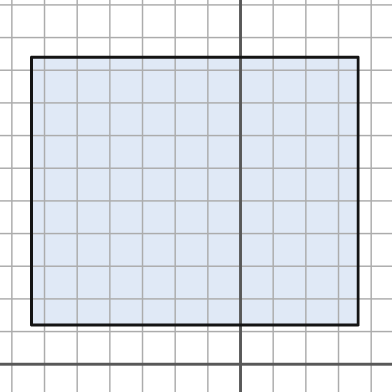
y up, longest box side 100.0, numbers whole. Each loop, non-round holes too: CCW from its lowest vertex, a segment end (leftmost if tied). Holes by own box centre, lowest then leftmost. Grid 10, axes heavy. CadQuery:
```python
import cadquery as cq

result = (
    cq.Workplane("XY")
    .moveTo(-64.0, 12.0)
    .lineTo(36.0, 12.0)
    .lineTo(36.0, 94.0)
    .lineTo(-64.0, 94.0)
    .close()
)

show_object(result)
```